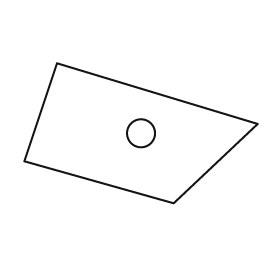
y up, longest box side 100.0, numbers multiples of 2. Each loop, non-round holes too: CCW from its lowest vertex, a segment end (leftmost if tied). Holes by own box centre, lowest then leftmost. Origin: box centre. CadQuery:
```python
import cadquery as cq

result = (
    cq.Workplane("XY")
    .moveTo(14.0, -30.0)
    .lineTo(50.0, 4.0)
    .lineTo(-36.0, 30.0)
    .lineTo(-50.0, -12.0)
    .close()
    .moveTo(0.0, 0.0)
    .circle(6.0)
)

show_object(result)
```